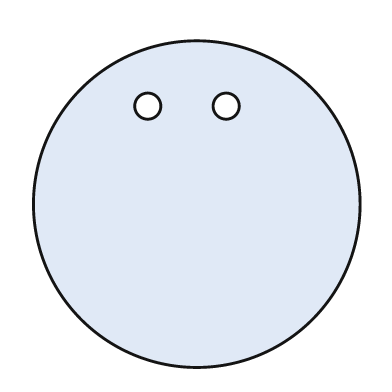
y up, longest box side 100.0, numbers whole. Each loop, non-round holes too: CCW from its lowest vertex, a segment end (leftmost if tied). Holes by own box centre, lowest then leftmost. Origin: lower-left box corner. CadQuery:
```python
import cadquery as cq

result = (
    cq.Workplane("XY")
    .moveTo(50.0, 50.0)
    .circle(50.0)
    .moveTo(35.0, 80.0)
    .circle(4.0)
    .moveTo(59.0, 80.0)
    .circle(4.0)
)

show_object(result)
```